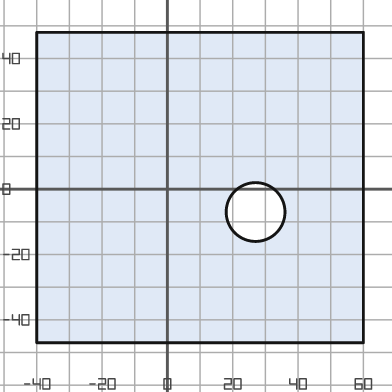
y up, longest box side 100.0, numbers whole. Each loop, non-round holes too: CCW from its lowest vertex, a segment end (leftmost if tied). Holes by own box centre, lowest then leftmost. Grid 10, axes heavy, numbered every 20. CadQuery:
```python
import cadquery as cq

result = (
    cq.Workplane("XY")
    .moveTo(-40.0, -47.0)
    .lineTo(60.0, -47.0)
    .lineTo(60.0, 48.0)
    .lineTo(-40.0, 48.0)
    .close()
    .moveTo(27.0, -7.0)
    .circle(9.0)
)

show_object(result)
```